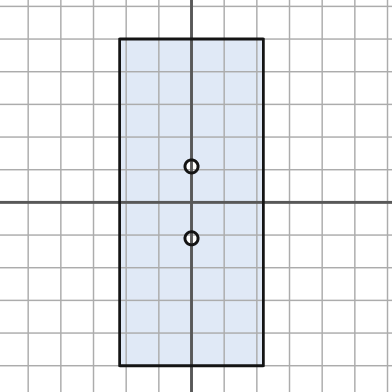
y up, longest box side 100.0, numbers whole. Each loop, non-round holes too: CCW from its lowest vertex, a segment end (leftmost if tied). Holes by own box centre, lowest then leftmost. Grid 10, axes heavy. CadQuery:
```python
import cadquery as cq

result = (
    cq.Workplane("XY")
    .moveTo(-22.0, -50.0)
    .lineTo(22.0, -50.0)
    .lineTo(22.0, 50.0)
    .lineTo(-22.0, 50.0)
    .close()
    .moveTo(0.0, -11.0)
    .circle(2.0)
    .moveTo(0.0, 11.0)
    .circle(2.0)
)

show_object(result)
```